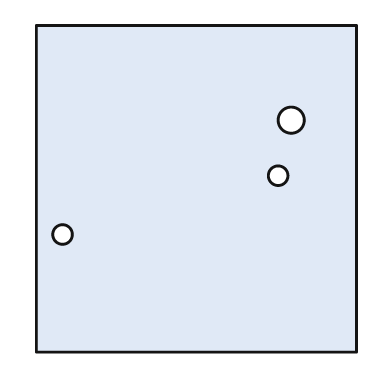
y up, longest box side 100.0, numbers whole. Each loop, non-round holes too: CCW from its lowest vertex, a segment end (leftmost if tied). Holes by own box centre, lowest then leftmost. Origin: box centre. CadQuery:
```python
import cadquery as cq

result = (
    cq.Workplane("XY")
    .moveTo(-49.0, -50.0)
    .lineTo(49.0, -50.0)
    .lineTo(49.0, 50.0)
    .lineTo(-49.0, 50.0)
    .close()
    .moveTo(-41.0, -14.0)
    .circle(3.0)
    .moveTo(25.0, 4.0)
    .circle(3.0)
    .moveTo(29.0, 21.0)
    .circle(4.0)
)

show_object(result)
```